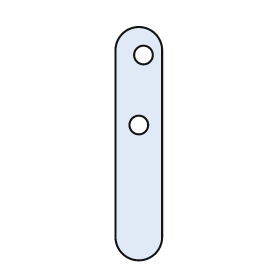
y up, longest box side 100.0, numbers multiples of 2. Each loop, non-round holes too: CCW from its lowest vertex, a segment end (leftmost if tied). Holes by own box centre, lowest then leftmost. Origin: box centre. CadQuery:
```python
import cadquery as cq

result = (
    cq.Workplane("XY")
    .moveTo(-10.0, -40.0)
    .threePointArc((0.0, -50.0), (10.0, -40.0))
    .lineTo(10.0, 40.0)
    .threePointArc((0.0, 50.0), (-10.0, 40.0))
    .close()
    .moveTo(0.0, 8.0)
    .circle(4.0)
    .moveTo(2.0, 38.0)
    .circle(4.0)
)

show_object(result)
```